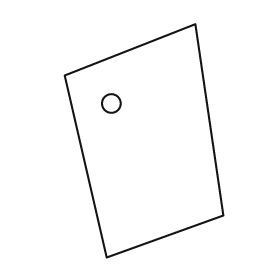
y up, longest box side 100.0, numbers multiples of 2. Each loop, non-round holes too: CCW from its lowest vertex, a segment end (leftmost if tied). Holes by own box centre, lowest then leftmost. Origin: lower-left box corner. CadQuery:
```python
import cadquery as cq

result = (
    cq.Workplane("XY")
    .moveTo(18.0, 0.0)
    .lineTo(68.0, 18.0)
    .lineTo(56.0, 100.0)
    .lineTo(0.0, 78.0)
    .close()
    .moveTo(20.0, 66.0)
    .circle(4.0)
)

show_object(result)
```